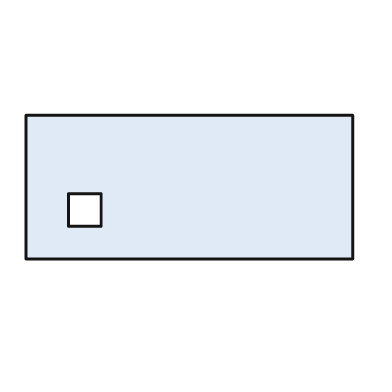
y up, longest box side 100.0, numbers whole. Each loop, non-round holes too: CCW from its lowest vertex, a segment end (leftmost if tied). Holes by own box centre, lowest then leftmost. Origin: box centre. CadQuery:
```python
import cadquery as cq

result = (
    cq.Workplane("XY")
    .moveTo(-50.0, -22.0)
    .lineTo(50.0, -22.0)
    .lineTo(50.0, 22.0)
    .lineTo(-50.0, 22.0)
    .close()
    .moveTo(-37.0, -12.0)
    .lineTo(-27.0, -12.0)
    .lineTo(-27.0, -2.0)
    .lineTo(-37.0, -2.0)
    .close()
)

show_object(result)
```